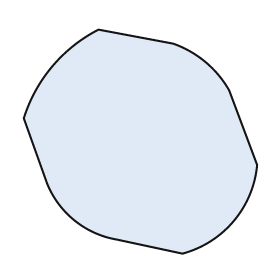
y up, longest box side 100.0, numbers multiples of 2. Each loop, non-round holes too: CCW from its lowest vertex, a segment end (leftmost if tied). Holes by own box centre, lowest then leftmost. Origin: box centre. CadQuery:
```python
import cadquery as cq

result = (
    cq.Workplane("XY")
    .moveTo(18.0, -48.0)
    .threePointArc((40.0, -34.0), (50.0, -10.0))
    .lineTo(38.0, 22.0)
    .threePointArc((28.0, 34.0), (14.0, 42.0))
    .lineTo(-18.0, 48.0)
    .threePointArc((-38.0, 32.0), (-50.0, 10.0))
    .lineTo(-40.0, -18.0)
    .threePointArc((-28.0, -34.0), (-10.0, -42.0))
    .close()
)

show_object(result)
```